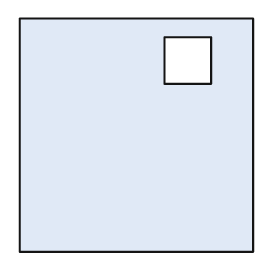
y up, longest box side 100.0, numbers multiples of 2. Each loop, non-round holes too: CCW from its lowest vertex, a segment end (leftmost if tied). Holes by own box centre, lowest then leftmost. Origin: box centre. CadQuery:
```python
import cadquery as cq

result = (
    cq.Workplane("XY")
    .moveTo(-50.0, -50.0)
    .lineTo(50.0, -50.0)
    .lineTo(50.0, 50.0)
    .lineTo(-50.0, 50.0)
    .close()
    .moveTo(12.0, 22.0)
    .lineTo(32.0, 22.0)
    .lineTo(32.0, 42.0)
    .lineTo(12.0, 42.0)
    .close()
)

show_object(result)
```